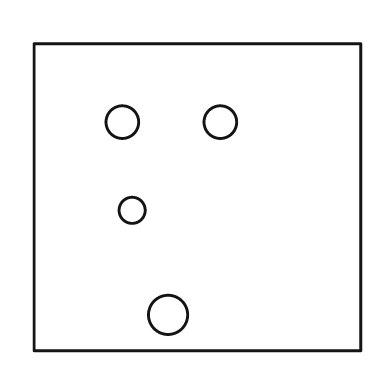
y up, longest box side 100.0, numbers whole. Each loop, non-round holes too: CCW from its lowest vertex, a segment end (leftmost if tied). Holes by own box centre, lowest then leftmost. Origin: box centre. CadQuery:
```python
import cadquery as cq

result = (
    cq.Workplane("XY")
    .moveTo(-50.0, -47.0)
    .lineTo(50.0, -47.0)
    .lineTo(50.0, 47.0)
    .lineTo(-50.0, 47.0)
    .close()
    .moveTo(-9.0, -36.0)
    .circle(6.0)
    .moveTo(-20.0, -4.0)
    .circle(4.0)
    .moveTo(-23.0, 23.0)
    .circle(5.0)
    .moveTo(7.0, 23.0)
    .circle(5.0)
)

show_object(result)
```